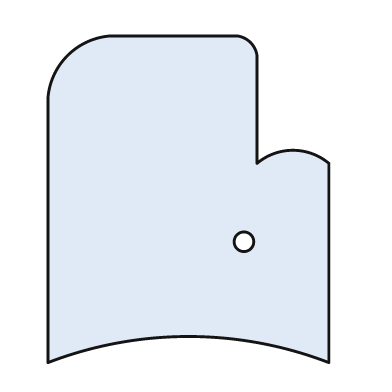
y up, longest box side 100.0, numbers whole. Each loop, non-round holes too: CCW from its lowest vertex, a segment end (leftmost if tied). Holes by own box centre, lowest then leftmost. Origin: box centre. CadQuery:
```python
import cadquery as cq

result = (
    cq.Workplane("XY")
    .moveTo(-43.0, -50.0)
    .threePointArc((0.0, -42.0), (43.0, -50.0))
    .lineTo(43.0, 11.0)
    .threePointArc((32.0, 15.0), (21.0, 11.0))
    .lineTo(21.0, 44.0)
    .threePointArc((19.0, 48.0), (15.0, 50.0))
    .lineTo(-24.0, 50.0)
    .threePointArc((-37.0, 44.0), (-43.0, 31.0))
    .close()
    .moveTo(17.0, -13.0)
    .circle(3.0)
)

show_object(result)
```